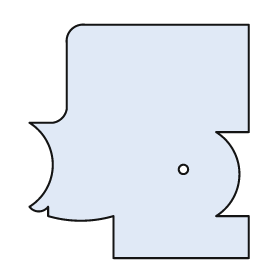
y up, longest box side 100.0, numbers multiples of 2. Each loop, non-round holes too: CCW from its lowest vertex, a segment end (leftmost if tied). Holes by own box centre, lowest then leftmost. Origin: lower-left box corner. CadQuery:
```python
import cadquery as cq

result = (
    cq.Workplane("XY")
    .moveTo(36.0, 0.0)
    .lineTo(94.0, 0.0)
    .lineTo(94.0, 18.0)
    .lineTo(80.0, 18.0)
    .threePointArc((90.0, 36.0), (80.0, 54.0))
    .lineTo(94.0, 54.0)
    .lineTo(94.0, 100.0)
    .lineTo(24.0, 100.0)
    .threePointArc((18.0, 98.0), (16.0, 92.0))
    .lineTo(16.0, 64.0)
    .threePointArc((14.0, 60.0), (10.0, 58.0))
    .lineTo(0.0, 58.0)
    .threePointArc((10.0, 40.0), (0.0, 22.0))
    .threePointArc((4.0, 20.0), (8.0, 22.0))
    .lineTo(8.0, 18.0)
    .threePointArc((22.0, 16.0), (36.0, 18.0))
    .close()
    .moveTo(66.0, 38.0)
    .circle(2.0)
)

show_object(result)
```